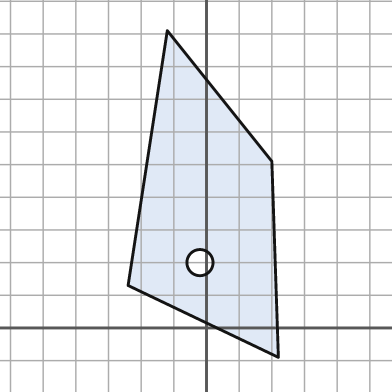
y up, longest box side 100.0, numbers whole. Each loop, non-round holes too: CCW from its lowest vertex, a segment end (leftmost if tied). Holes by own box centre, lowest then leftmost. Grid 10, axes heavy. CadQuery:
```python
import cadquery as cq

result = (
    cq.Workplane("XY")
    .moveTo(22.0, -9.0)
    .lineTo(20.0, 51.0)
    .lineTo(-12.0, 91.0)
    .lineTo(-24.0, 13.0)
    .close()
    .moveTo(-2.0, 20.0)
    .circle(4.0)
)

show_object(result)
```